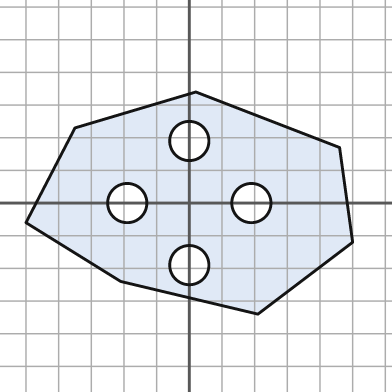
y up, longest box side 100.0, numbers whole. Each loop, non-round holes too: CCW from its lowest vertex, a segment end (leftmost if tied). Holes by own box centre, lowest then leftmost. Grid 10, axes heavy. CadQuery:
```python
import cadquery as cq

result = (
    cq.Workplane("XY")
    .moveTo(21.0, -34.0)
    .lineTo(50.0, -12.0)
    .lineTo(46.0, 17.0)
    .lineTo(2.0, 34.0)
    .lineTo(-35.0, 23.0)
    .lineTo(-50.0, -6.0)
    .lineTo(-21.0, -24.0)
    .close()
    .moveTo(0.0, -19.0)
    .circle(6.0)
    .moveTo(-19.0, 0.0)
    .circle(6.0)
    .moveTo(19.0, 0.0)
    .circle(6.0)
    .moveTo(0.0, 19.0)
    .circle(6.0)
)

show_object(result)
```